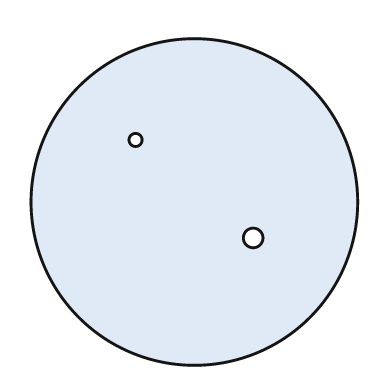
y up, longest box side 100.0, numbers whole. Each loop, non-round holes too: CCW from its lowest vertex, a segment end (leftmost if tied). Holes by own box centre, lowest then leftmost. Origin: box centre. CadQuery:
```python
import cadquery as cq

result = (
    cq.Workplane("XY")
    .moveTo(0.0, 0.0)
    .circle(50.0)
    .moveTo(18.0, -11.0)
    .circle(3.0)
    .moveTo(-18.0, 19.0)
    .circle(2.0)
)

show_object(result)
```